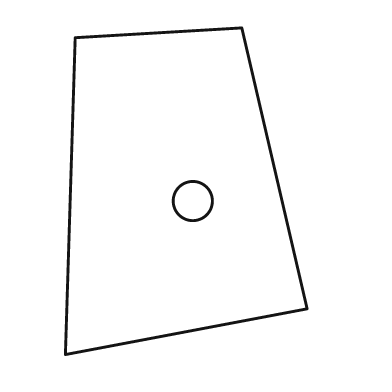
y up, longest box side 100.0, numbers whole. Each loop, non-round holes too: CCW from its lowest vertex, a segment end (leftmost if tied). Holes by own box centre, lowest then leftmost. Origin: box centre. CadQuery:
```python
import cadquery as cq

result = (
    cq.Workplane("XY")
    .moveTo(-37.0, -50.0)
    .lineTo(37.0, -36.0)
    .lineTo(17.0, 50.0)
    .lineTo(-34.0, 47.0)
    .close()
    .moveTo(2.0, -3.0)
    .circle(6.0)
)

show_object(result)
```